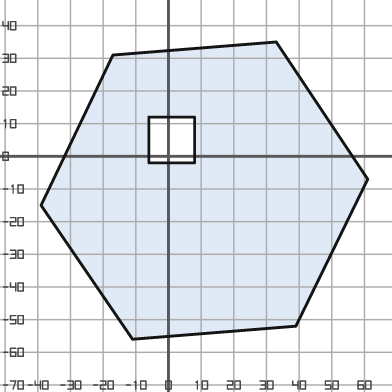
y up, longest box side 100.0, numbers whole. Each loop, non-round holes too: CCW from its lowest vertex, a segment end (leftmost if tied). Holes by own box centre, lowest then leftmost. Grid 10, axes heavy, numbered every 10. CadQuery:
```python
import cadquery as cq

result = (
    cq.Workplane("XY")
    .moveTo(-11.0, -56.0)
    .lineTo(39.0, -52.0)
    .lineTo(61.0, -7.0)
    .lineTo(33.0, 35.0)
    .lineTo(-17.0, 31.0)
    .lineTo(-39.0, -15.0)
    .close()
    .moveTo(-6.0, -2.0)
    .lineTo(8.0, -2.0)
    .lineTo(8.0, 12.0)
    .lineTo(-6.0, 12.0)
    .close()
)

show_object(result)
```